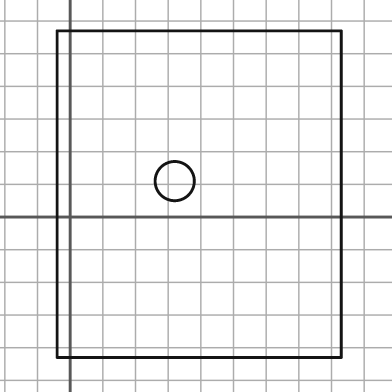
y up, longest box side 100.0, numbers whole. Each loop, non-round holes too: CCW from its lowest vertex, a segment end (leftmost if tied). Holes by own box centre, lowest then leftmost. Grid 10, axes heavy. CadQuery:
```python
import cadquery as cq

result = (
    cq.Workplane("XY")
    .moveTo(-4.0, -43.0)
    .lineTo(83.0, -43.0)
    .lineTo(83.0, 57.0)
    .lineTo(-4.0, 57.0)
    .close()
    .moveTo(32.0, 11.0)
    .circle(6.0)
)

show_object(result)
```